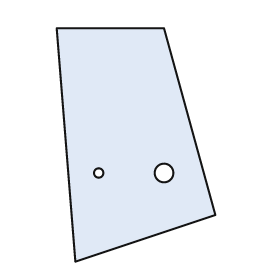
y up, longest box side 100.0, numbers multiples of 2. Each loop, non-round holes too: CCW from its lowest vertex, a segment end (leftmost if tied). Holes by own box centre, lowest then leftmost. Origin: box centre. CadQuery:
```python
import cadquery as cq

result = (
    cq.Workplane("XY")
    .moveTo(-26.0, -50.0)
    .lineTo(34.0, -30.0)
    .lineTo(12.0, 50.0)
    .lineTo(-34.0, 50.0)
    .close()
    .moveTo(-16.0, -12.0)
    .circle(2.0)
    .moveTo(12.0, -12.0)
    .circle(4.0)
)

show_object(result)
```